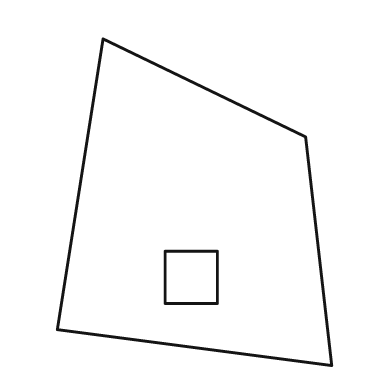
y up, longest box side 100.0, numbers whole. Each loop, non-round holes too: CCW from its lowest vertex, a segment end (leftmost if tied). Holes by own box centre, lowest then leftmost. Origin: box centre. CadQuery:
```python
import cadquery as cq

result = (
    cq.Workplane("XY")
    .moveTo(42.0, -50.0)
    .lineTo(34.0, 20.0)
    .lineTo(-28.0, 50.0)
    .lineTo(-42.0, -39.0)
    .close()
    .moveTo(-9.0, -31.0)
    .lineTo(7.0, -31.0)
    .lineTo(7.0, -15.0)
    .lineTo(-9.0, -15.0)
    .close()
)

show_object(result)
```